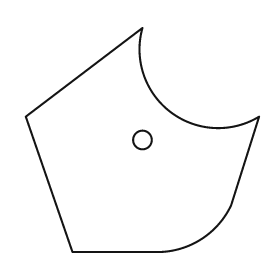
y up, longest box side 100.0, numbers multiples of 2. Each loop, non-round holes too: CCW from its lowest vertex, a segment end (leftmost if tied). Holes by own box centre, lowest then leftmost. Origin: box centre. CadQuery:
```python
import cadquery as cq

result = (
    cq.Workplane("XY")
    .moveTo(-30.0, -48.0)
    .lineTo(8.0, -48.0)
    .threePointArc((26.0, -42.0), (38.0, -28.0))
    .lineTo(50.0, 10.0)
    .threePointArc((12.0, 12.0), (0.0, 48.0))
    .lineTo(-50.0, 10.0)
    .close()
    .moveTo(0.0, 0.0)
    .circle(4.0)
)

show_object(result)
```